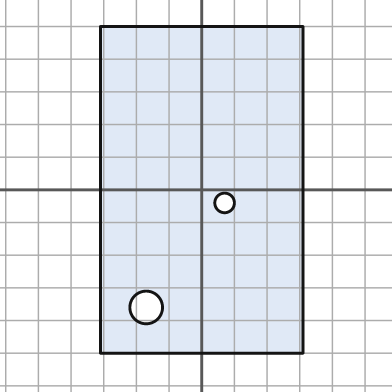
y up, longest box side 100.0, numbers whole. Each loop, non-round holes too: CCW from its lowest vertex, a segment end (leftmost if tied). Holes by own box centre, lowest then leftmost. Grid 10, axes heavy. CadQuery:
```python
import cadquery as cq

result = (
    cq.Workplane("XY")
    .moveTo(-31.0, -50.0)
    .lineTo(31.0, -50.0)
    .lineTo(31.0, 50.0)
    .lineTo(-31.0, 50.0)
    .close()
    .moveTo(-17.0, -36.0)
    .circle(5.0)
    .moveTo(7.0, -4.0)
    .circle(3.0)
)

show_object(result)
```